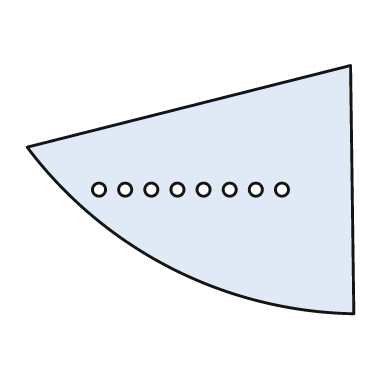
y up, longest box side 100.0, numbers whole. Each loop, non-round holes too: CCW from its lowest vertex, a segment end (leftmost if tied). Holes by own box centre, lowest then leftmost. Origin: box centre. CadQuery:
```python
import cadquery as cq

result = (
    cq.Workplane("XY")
    .moveTo(50.0, -38.0)
    .lineTo(49.0, 38.0)
    .lineTo(-50.0, 13.0)
    .threePointArc((-6.0, -24.0), (50.0, -38.0))
    .close()
    .moveTo(-28.0, 0.0)
    .circle(2.0)
    .moveTo(-20.0, 0.0)
    .circle(2.0)
    .moveTo(-12.0, 0.0)
    .circle(2.0)
    .moveTo(-4.0, 0.0)
    .circle(2.0)
    .moveTo(4.0, 0.0)
    .circle(2.0)
    .moveTo(12.0, 0.0)
    .circle(2.0)
    .moveTo(20.0, 0.0)
    .circle(2.0)
    .moveTo(28.0, 0.0)
    .circle(2.0)
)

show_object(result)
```